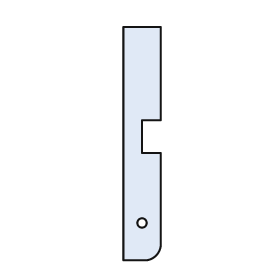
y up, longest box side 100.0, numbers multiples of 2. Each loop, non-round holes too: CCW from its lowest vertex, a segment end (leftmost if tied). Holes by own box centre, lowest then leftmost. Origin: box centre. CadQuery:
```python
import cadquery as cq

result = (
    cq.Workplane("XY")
    .moveTo(-8.0, -50.0)
    .lineTo(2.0, -50.0)
    .threePointArc((6.0, -48.0), (8.0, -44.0))
    .lineTo(8.0, -4.0)
    .lineTo(0.0, -4.0)
    .lineTo(0.0, 10.0)
    .lineTo(8.0, 10.0)
    .lineTo(8.0, 50.0)
    .lineTo(-8.0, 50.0)
    .close()
    .moveTo(0.0, -34.0)
    .circle(2.0)
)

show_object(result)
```